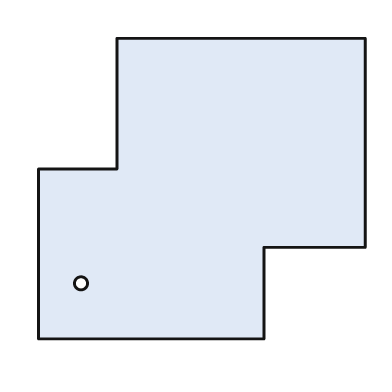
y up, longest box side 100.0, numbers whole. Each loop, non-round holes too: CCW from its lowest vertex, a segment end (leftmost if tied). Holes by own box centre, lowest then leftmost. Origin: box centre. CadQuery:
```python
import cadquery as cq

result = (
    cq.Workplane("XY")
    .moveTo(-50.0, -46.0)
    .lineTo(19.0, -46.0)
    .lineTo(19.0, -18.0)
    .lineTo(50.0, -18.0)
    .lineTo(50.0, 46.0)
    .lineTo(-26.0, 46.0)
    .lineTo(-26.0, 6.0)
    .lineTo(-50.0, 6.0)
    .close()
    .moveTo(-37.0, -29.0)
    .circle(2.0)
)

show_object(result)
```